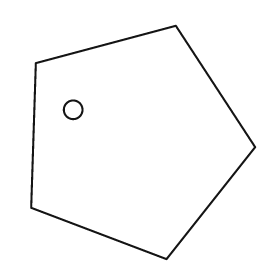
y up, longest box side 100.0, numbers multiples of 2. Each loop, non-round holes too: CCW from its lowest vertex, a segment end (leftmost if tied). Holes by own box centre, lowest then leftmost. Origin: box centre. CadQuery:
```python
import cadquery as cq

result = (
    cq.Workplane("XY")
    .moveTo(10.0, -50.0)
    .lineTo(48.0, -2.0)
    .lineTo(14.0, 50.0)
    .lineTo(-46.0, 34.0)
    .lineTo(-48.0, -28.0)
    .close()
    .moveTo(-30.0, 14.0)
    .circle(4.0)
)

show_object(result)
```